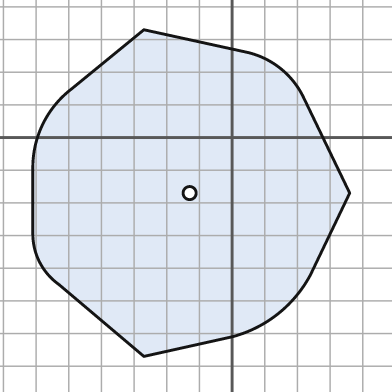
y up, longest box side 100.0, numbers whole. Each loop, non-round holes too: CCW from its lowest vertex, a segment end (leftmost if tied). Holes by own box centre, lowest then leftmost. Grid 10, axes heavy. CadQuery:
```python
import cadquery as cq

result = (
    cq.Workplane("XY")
    .moveTo(-27.0, -67.0)
    .lineTo(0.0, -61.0)
    .threePointArc((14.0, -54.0), (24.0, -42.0))
    .lineTo(36.0, -17.0)
    .lineTo(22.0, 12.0)
    .threePointArc((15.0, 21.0), (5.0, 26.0))
    .lineTo(-27.0, 33.0)
    .lineTo(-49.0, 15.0)
    .threePointArc((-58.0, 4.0), (-61.0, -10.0))
    .lineTo(-61.0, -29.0)
    .threePointArc((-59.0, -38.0), (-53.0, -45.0))
    .close()
    .moveTo(-13.0, -17.0)
    .circle(2.0)
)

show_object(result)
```